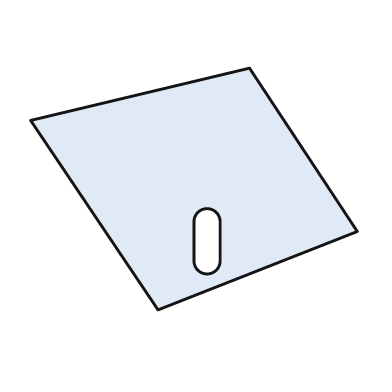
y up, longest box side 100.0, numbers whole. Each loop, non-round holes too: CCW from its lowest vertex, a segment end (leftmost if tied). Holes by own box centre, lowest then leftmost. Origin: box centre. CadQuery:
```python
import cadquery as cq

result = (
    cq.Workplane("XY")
    .moveTo(-11.0, -37.0)
    .lineTo(50.0, -13.0)
    .lineTo(17.0, 37.0)
    .lineTo(-50.0, 21.0)
    .close()
    .moveTo(0.0, -22.0)
    .threePointArc((4.0, -26.0), (8.0, -22.0))
    .lineTo(8.0, -10.0)
    .threePointArc((4.0, -6.0), (0.0, -10.0))
    .close()
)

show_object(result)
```